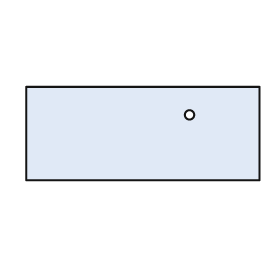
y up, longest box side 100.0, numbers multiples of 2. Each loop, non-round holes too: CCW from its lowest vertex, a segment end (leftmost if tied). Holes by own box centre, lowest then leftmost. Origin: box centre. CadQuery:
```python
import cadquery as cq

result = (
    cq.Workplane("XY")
    .moveTo(-50.0, -20.0)
    .lineTo(50.0, -20.0)
    .lineTo(50.0, 20.0)
    .lineTo(-50.0, 20.0)
    .close()
    .moveTo(20.0, 8.0)
    .circle(2.0)
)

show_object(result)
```